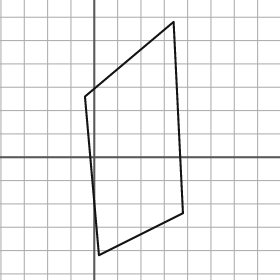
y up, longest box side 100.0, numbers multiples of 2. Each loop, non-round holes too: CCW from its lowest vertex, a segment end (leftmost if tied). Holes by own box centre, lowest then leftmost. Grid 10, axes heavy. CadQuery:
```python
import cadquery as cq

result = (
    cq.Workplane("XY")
    .moveTo(2.0, -42.0)
    .lineTo(38.0, -24.0)
    .lineTo(34.0, 58.0)
    .lineTo(-4.0, 26.0)
    .close()
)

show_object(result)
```